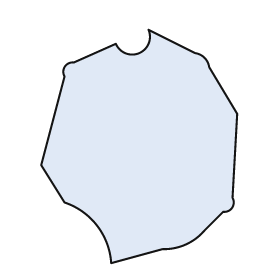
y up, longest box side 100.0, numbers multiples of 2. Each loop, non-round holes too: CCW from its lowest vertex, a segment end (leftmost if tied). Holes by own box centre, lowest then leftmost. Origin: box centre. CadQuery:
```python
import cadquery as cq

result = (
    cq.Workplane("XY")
    .moveTo(-12.0, -50.0)
    .lineTo(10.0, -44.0)
    .threePointArc((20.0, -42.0), (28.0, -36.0))
    .lineTo(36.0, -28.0)
    .threePointArc((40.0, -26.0), (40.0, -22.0))
    .lineTo(42.0, 14.0)
    .lineTo(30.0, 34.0)
    .threePointArc((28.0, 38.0), (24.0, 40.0))
    .lineTo(4.0, 50.0)
    .threePointArc((0.0, 40.0), (-10.0, 44.0))
    .lineTo(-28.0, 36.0)
    .threePointArc((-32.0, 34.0), (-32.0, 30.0))
    .lineTo(-42.0, -8.0)
    .lineTo(-32.0, -24.0)
    .threePointArc((-18.0, -34.0), (-12.0, -50.0))
    .close()
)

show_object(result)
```